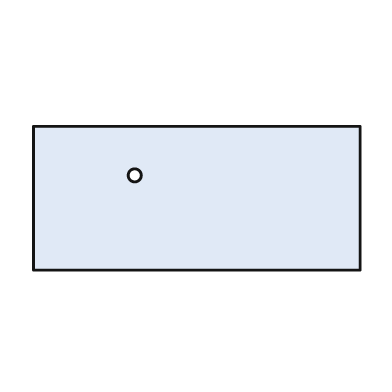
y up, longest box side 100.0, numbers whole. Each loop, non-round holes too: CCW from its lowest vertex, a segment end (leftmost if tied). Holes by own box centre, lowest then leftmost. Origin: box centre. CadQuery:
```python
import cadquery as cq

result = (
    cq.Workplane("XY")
    .moveTo(-50.0, -22.0)
    .lineTo(50.0, -22.0)
    .lineTo(50.0, 22.0)
    .lineTo(-50.0, 22.0)
    .close()
    .moveTo(-19.0, 7.0)
    .circle(2.0)
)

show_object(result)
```